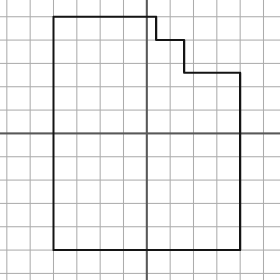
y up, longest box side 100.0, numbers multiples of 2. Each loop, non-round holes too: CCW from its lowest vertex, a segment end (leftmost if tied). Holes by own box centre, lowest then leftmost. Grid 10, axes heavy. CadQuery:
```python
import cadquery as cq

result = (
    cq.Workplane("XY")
    .moveTo(-40.0, -50.0)
    .lineTo(40.0, -50.0)
    .lineTo(40.0, 26.0)
    .lineTo(16.0, 26.0)
    .lineTo(16.0, 40.0)
    .lineTo(4.0, 40.0)
    .lineTo(4.0, 50.0)
    .lineTo(-40.0, 50.0)
    .close()
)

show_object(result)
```